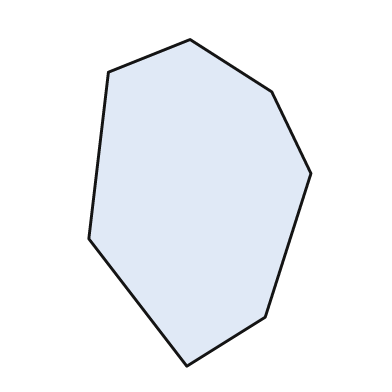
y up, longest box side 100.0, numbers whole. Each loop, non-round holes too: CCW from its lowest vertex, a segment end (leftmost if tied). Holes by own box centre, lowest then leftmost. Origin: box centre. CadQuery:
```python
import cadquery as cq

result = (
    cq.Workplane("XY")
    .moveTo(-4.0, -50.0)
    .lineTo(20.0, -35.0)
    .lineTo(34.0, 9.0)
    .lineTo(22.0, 34.0)
    .lineTo(-3.0, 50.0)
    .lineTo(-28.0, 40.0)
    .lineTo(-34.0, -11.0)
    .close()
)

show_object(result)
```